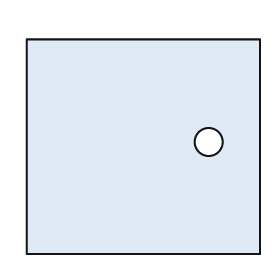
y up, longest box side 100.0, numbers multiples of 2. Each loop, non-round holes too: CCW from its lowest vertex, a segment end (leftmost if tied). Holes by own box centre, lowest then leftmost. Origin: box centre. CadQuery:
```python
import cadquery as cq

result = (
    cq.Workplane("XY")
    .moveTo(-50.0, -46.0)
    .lineTo(50.0, -46.0)
    .lineTo(50.0, 46.0)
    .lineTo(-50.0, 46.0)
    .close()
    .moveTo(28.0, 2.0)
    .circle(6.0)
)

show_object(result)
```